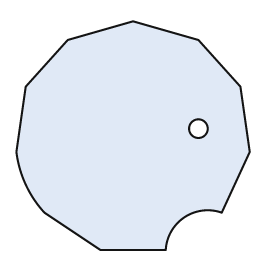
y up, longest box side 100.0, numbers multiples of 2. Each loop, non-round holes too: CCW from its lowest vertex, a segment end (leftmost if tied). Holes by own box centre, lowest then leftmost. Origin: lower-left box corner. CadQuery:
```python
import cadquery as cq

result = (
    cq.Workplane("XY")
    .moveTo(36.0, 0.0)
    .lineTo(64.0, 0.0)
    .threePointArc((72.0, 14.0), (88.0, 16.0))
    .lineTo(100.0, 42.0)
    .lineTo(96.0, 70.0)
    .lineTo(78.0, 90.0)
    .lineTo(50.0, 98.0)
    .lineTo(22.0, 90.0)
    .lineTo(4.0, 70.0)
    .lineTo(0.0, 42.0)
    .threePointArc((4.0, 28.0), (12.0, 16.0))
    .close()
    .moveTo(78.0, 52.0)
    .circle(4.0)
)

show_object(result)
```